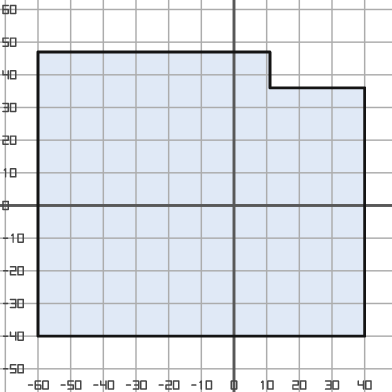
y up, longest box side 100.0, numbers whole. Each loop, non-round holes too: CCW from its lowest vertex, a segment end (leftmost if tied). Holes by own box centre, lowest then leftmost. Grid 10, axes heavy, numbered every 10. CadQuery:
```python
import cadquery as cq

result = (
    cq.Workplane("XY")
    .moveTo(-60.0, -40.0)
    .lineTo(40.0, -40.0)
    .lineTo(40.0, 36.0)
    .lineTo(11.0, 36.0)
    .lineTo(11.0, 47.0)
    .lineTo(-60.0, 47.0)
    .close()
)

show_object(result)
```